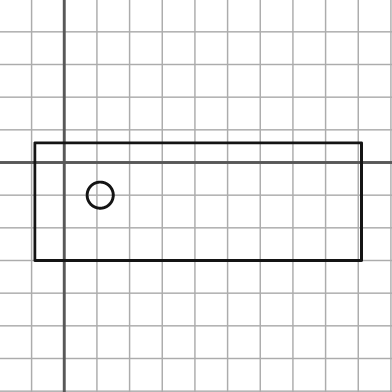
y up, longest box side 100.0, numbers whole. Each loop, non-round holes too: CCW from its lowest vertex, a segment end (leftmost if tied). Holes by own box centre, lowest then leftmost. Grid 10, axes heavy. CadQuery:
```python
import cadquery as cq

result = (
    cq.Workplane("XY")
    .moveTo(-9.0, -30.0)
    .lineTo(91.0, -30.0)
    .lineTo(91.0, 6.0)
    .lineTo(-9.0, 6.0)
    .close()
    .moveTo(11.0, -10.0)
    .circle(4.0)
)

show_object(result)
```